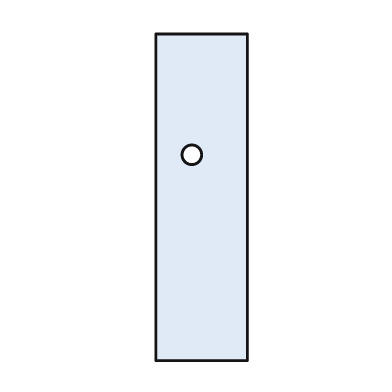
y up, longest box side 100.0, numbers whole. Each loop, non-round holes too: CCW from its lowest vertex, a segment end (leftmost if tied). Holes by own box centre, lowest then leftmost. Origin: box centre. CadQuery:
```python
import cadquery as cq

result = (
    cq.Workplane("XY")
    .moveTo(-14.0, -50.0)
    .lineTo(14.0, -50.0)
    .lineTo(14.0, 50.0)
    .lineTo(-14.0, 50.0)
    .close()
    .moveTo(-3.0, 13.0)
    .circle(3.0)
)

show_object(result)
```